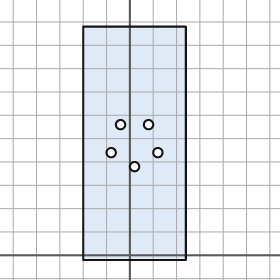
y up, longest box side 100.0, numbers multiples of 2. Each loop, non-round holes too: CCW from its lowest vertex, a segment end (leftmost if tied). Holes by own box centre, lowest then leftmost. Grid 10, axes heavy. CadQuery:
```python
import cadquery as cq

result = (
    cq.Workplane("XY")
    .moveTo(-20.0, -2.0)
    .lineTo(24.0, -2.0)
    .lineTo(24.0, 98.0)
    .lineTo(-20.0, 98.0)
    .close()
    .moveTo(2.0, 38.0)
    .circle(2.0)
    .moveTo(-8.0, 44.0)
    .circle(2.0)
    .moveTo(12.0, 44.0)
    .circle(2.0)
    .moveTo(-4.0, 56.0)
    .circle(2.0)
    .moveTo(8.0, 56.0)
    .circle(2.0)
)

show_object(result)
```